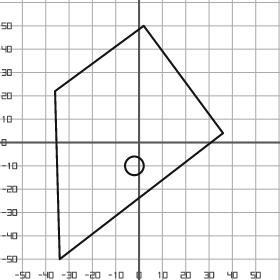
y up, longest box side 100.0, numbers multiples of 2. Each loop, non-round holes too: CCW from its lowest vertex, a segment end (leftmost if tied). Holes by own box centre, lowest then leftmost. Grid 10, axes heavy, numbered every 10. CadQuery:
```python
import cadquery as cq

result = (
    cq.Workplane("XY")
    .moveTo(-34.0, -50.0)
    .lineTo(36.0, 4.0)
    .lineTo(2.0, 50.0)
    .lineTo(-36.0, 22.0)
    .close()
    .moveTo(-2.0, -10.0)
    .circle(4.0)
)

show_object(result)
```